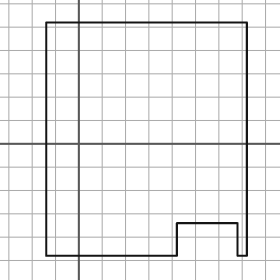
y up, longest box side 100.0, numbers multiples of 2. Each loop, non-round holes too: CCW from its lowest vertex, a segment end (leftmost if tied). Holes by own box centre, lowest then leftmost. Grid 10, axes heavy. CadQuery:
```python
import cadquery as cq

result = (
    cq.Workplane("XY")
    .moveTo(-14.0, -48.0)
    .lineTo(42.0, -48.0)
    .lineTo(42.0, -34.0)
    .lineTo(68.0, -34.0)
    .lineTo(68.0, -48.0)
    .lineTo(72.0, -48.0)
    .lineTo(72.0, 52.0)
    .lineTo(-14.0, 52.0)
    .close()
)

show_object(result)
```